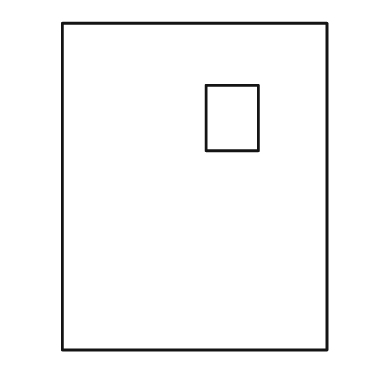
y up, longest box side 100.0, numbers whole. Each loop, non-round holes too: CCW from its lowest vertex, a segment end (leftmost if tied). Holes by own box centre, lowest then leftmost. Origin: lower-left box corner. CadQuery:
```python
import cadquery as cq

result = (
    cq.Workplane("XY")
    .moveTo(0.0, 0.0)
    .lineTo(81.0, 0.0)
    .lineTo(81.0, 100.0)
    .lineTo(0.0, 100.0)
    .close()
    .moveTo(44.0, 61.0)
    .lineTo(60.0, 61.0)
    .lineTo(60.0, 81.0)
    .lineTo(44.0, 81.0)
    .close()
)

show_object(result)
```